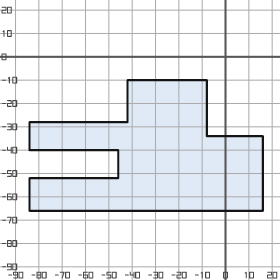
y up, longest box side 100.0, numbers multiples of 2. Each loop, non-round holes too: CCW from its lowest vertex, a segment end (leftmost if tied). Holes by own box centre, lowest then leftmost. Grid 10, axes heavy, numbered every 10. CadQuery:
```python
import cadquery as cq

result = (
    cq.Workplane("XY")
    .moveTo(-84.0, -66.0)
    .lineTo(16.0, -66.0)
    .lineTo(16.0, -34.0)
    .lineTo(-8.0, -34.0)
    .lineTo(-8.0, -10.0)
    .lineTo(-42.0, -10.0)
    .lineTo(-42.0, -28.0)
    .lineTo(-84.0, -28.0)
    .lineTo(-84.0, -40.0)
    .lineTo(-46.0, -40.0)
    .lineTo(-46.0, -52.0)
    .lineTo(-84.0, -52.0)
    .close()
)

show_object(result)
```